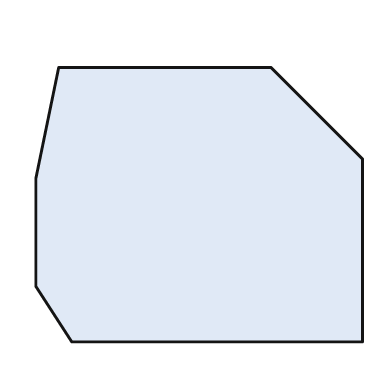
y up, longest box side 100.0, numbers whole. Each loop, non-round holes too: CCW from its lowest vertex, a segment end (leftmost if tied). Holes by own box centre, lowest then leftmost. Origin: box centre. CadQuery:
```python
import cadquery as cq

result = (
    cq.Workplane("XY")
    .moveTo(-39.0, -42.0)
    .lineTo(50.0, -42.0)
    .lineTo(50.0, 14.0)
    .lineTo(22.0, 42.0)
    .lineTo(-43.0, 42.0)
    .lineTo(-50.0, 8.0)
    .lineTo(-50.0, -25.0)
    .close()
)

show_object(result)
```